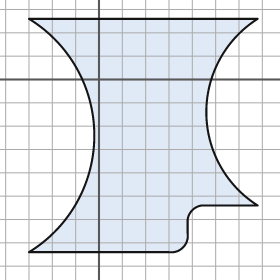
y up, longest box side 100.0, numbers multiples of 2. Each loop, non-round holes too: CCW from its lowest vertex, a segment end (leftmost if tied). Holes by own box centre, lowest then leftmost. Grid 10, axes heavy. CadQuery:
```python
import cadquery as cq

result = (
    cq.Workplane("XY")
    .moveTo(-30.0, -74.0)
    .lineTo(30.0, -74.0)
    .threePointArc((36.0, -72.0), (38.0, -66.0))
    .lineTo(38.0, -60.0)
    .threePointArc((40.0, -56.0), (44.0, -54.0))
    .lineTo(68.0, -54.0)
    .threePointArc((46.0, -14.0), (68.0, 26.0))
    .lineTo(-30.0, 26.0)
    .threePointArc((-2.0, -24.0), (-30.0, -74.0))
    .close()
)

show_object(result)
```